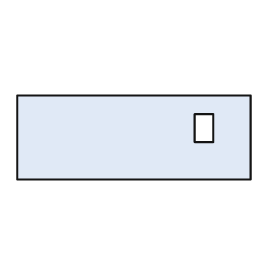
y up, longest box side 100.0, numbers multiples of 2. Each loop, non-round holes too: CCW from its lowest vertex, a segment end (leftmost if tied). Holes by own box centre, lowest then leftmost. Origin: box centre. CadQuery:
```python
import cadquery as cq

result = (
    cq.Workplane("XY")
    .moveTo(-50.0, -18.0)
    .lineTo(50.0, -18.0)
    .lineTo(50.0, 18.0)
    .lineTo(-50.0, 18.0)
    .close()
    .moveTo(26.0, -2.0)
    .lineTo(34.0, -2.0)
    .lineTo(34.0, 10.0)
    .lineTo(26.0, 10.0)
    .close()
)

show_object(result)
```